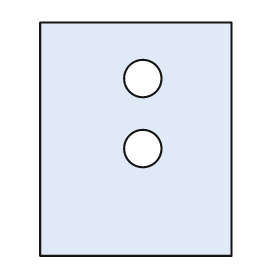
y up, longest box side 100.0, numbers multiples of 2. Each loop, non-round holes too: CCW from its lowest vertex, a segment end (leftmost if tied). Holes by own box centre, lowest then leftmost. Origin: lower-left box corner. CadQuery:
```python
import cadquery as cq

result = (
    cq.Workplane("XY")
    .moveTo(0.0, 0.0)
    .lineTo(82.0, 0.0)
    .lineTo(82.0, 100.0)
    .lineTo(0.0, 100.0)
    .close()
    .moveTo(44.0, 46.0)
    .circle(8.0)
    .moveTo(44.0, 76.0)
    .circle(8.0)
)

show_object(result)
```